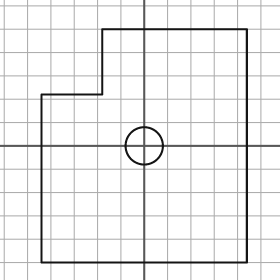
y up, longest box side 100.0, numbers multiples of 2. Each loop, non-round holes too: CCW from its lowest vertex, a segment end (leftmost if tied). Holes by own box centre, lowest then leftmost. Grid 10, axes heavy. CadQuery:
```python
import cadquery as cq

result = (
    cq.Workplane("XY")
    .moveTo(-44.0, -50.0)
    .lineTo(44.0, -50.0)
    .lineTo(44.0, 50.0)
    .lineTo(-18.0, 50.0)
    .lineTo(-18.0, 22.0)
    .lineTo(-44.0, 22.0)
    .close()
    .moveTo(0.0, 0.0)
    .circle(8.0)
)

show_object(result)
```